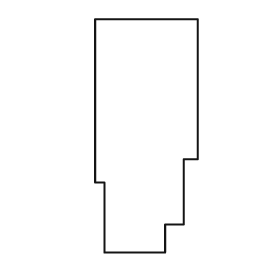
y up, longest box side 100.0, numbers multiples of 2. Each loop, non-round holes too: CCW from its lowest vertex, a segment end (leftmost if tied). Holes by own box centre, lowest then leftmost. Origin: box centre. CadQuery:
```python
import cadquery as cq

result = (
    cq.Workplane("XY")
    .moveTo(-18.0, -50.0)
    .lineTo(8.0, -50.0)
    .lineTo(8.0, -38.0)
    .lineTo(16.0, -38.0)
    .lineTo(16.0, -10.0)
    .lineTo(22.0, -10.0)
    .lineTo(22.0, 50.0)
    .lineTo(-22.0, 50.0)
    .lineTo(-22.0, -20.0)
    .lineTo(-18.0, -20.0)
    .close()
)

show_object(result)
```